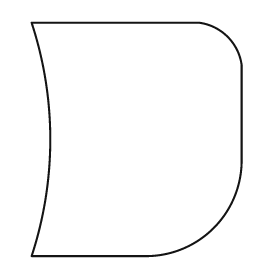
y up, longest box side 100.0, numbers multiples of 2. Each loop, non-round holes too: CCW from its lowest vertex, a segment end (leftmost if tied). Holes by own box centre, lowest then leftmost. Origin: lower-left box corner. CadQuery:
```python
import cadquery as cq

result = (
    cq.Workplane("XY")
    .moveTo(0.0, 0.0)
    .lineTo(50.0, 0.0)
    .threePointArc((78.0, 12.0), (90.0, 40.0))
    .lineTo(90.0, 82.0)
    .threePointArc((84.0, 94.0), (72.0, 100.0))
    .lineTo(0.0, 100.0)
    .threePointArc((8.0, 50.0), (0.0, 0.0))
    .close()
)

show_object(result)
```